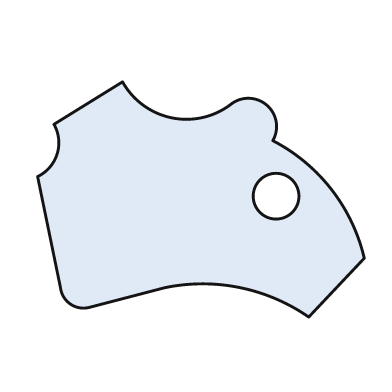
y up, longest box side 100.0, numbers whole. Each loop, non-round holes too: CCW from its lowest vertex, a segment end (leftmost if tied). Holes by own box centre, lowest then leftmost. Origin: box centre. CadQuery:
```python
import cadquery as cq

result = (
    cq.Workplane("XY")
    .moveTo(33.0, -36.0)
    .lineTo(50.0, -18.0)
    .threePointArc((40.0, 3.0), (22.0, 18.0))
    .threePointArc((20.0, 29.0), (9.0, 29.0))
    .threePointArc((-9.0, 25.0), (-24.0, 36.0))
    .lineTo(-45.0, 23.0)
    .threePointArc((-44.0, 14.0), (-50.0, 7.0))
    .lineTo(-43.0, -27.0)
    .threePointArc((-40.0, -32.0), (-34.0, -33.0))
    .lineTo(-11.0, -27.0)
    .threePointArc((12.0, -27.0), (33.0, -36.0))
    .close()
    .moveTo(23.0, 1.0)
    .circle(7.0)
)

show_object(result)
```